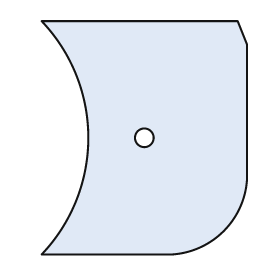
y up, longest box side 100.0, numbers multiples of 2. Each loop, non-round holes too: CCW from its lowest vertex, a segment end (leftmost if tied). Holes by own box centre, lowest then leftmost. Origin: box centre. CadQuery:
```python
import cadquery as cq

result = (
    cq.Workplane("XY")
    .moveTo(-44.0, -50.0)
    .lineTo(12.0, -50.0)
    .threePointArc((34.0, -40.0), (44.0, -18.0))
    .lineTo(44.0, 40.0)
    .lineTo(40.0, 50.0)
    .lineTo(-44.0, 50.0)
    .threePointArc((-24.0, 0.0), (-44.0, -50.0))
    .close()
    .moveTo(0.0, 0.0)
    .circle(4.0)
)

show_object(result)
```